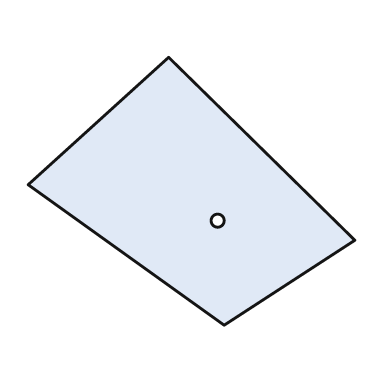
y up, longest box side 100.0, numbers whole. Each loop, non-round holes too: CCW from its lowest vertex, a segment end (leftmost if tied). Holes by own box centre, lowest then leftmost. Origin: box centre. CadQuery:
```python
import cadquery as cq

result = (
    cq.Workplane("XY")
    .moveTo(10.0, -41.0)
    .lineTo(50.0, -15.0)
    .lineTo(-7.0, 41.0)
    .lineTo(-50.0, 2.0)
    .close()
    .moveTo(8.0, -9.0)
    .circle(2.0)
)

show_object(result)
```